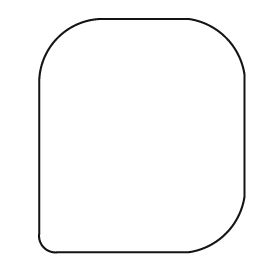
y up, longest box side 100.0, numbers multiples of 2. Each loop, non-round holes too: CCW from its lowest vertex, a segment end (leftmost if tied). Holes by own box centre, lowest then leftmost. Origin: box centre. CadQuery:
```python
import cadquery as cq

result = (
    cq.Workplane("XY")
    .moveTo(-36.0, -50.0)
    .lineTo(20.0, -50.0)
    .threePointArc((36.0, -42.0), (44.0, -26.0))
    .lineTo(44.0, 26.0)
    .threePointArc((36.0, 42.0), (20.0, 50.0))
    .lineTo(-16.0, 50.0)
    .threePointArc((-36.0, 42.0), (-44.0, 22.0))
    .lineTo(-44.0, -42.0)
    .threePointArc((-42.0, -48.0), (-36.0, -50.0))
    .close()
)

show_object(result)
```